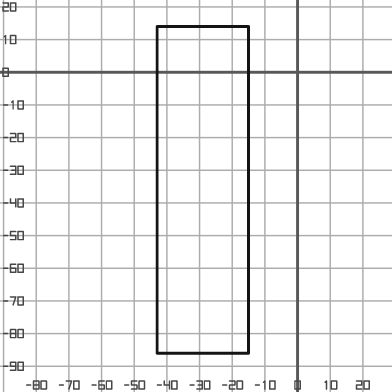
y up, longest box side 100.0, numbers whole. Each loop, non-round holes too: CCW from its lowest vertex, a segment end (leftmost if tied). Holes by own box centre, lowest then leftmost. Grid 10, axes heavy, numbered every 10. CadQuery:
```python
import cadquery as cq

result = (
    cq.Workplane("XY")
    .moveTo(-43.0, -86.0)
    .lineTo(-15.0, -86.0)
    .lineTo(-15.0, 14.0)
    .lineTo(-43.0, 14.0)
    .close()
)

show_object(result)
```